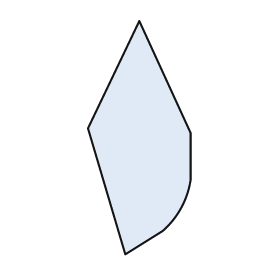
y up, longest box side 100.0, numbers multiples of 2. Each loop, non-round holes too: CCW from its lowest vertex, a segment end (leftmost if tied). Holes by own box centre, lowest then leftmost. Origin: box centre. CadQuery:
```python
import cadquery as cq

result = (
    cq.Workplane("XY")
    .moveTo(-6.0, -50.0)
    .lineTo(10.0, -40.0)
    .threePointArc((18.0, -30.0), (22.0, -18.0))
    .lineTo(22.0, 2.0)
    .lineTo(0.0, 50.0)
    .lineTo(-22.0, 4.0)
    .close()
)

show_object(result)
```